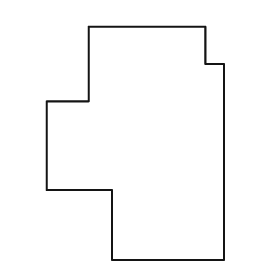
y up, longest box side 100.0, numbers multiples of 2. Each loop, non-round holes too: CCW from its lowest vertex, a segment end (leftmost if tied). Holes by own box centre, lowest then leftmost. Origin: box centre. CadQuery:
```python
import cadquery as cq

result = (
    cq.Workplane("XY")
    .moveTo(-10.0, -50.0)
    .lineTo(38.0, -50.0)
    .lineTo(38.0, 34.0)
    .lineTo(30.0, 34.0)
    .lineTo(30.0, 50.0)
    .lineTo(-20.0, 50.0)
    .lineTo(-20.0, 18.0)
    .lineTo(-38.0, 18.0)
    .lineTo(-38.0, -20.0)
    .lineTo(-10.0, -20.0)
    .close()
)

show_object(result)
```